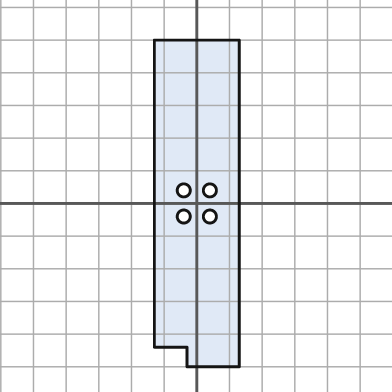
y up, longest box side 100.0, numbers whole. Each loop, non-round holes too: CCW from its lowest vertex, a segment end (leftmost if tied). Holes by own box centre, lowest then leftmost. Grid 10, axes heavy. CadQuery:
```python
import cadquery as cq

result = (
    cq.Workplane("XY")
    .moveTo(-3.0, -50.0)
    .lineTo(13.0, -50.0)
    .lineTo(13.0, 50.0)
    .lineTo(-13.0, 50.0)
    .lineTo(-13.0, -44.0)
    .lineTo(-3.0, -44.0)
    .close()
    .moveTo(-4.0, -4.0)
    .circle(2.0)
    .moveTo(4.0, -4.0)
    .circle(2.0)
    .moveTo(-4.0, 4.0)
    .circle(2.0)
    .moveTo(4.0, 4.0)
    .circle(2.0)
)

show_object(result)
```